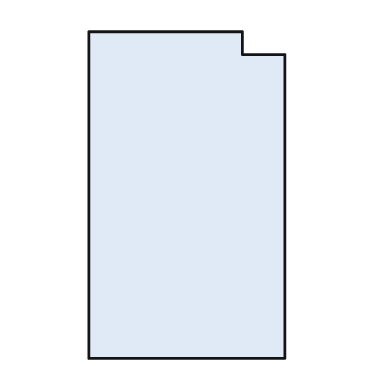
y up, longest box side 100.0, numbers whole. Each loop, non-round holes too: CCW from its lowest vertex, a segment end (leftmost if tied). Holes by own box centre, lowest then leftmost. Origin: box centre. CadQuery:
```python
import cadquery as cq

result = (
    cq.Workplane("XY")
    .moveTo(-30.0, -50.0)
    .lineTo(30.0, -50.0)
    .lineTo(30.0, 43.0)
    .lineTo(17.0, 43.0)
    .lineTo(17.0, 50.0)
    .lineTo(-30.0, 50.0)
    .close()
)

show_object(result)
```